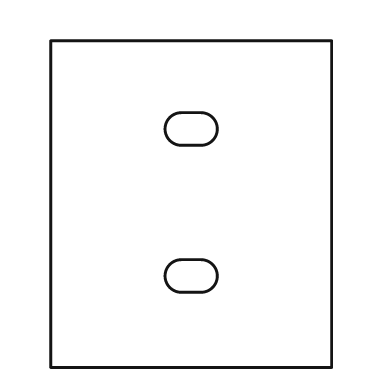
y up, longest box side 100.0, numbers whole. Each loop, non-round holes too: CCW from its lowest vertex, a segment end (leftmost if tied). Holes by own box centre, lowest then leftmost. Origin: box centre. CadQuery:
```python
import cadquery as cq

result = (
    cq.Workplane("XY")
    .moveTo(-43.0, -50.0)
    .lineTo(43.0, -50.0)
    .lineTo(43.0, 50.0)
    .lineTo(-43.0, 50.0)
    .close()
    .moveTo(-3.0, -27.0)
    .lineTo(3.0, -27.0)
    .threePointArc((8.0, -22.0), (3.0, -17.0))
    .lineTo(-3.0, -17.0)
    .threePointArc((-8.0, -22.0), (-3.0, -27.0))
    .close()
    .moveTo(-3.0, 18.0)
    .lineTo(3.0, 18.0)
    .threePointArc((8.0, 23.0), (3.0, 28.0))
    .lineTo(-3.0, 28.0)
    .threePointArc((-8.0, 23.0), (-3.0, 18.0))
    .close()
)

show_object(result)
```